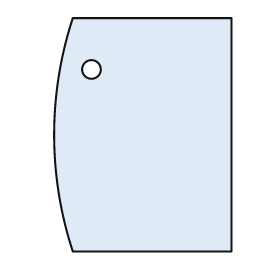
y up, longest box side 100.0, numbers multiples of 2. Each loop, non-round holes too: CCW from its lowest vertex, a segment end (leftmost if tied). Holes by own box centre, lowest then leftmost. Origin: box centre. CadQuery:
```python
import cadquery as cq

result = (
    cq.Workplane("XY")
    .moveTo(-30.0, -50.0)
    .lineTo(38.0, -50.0)
    .lineTo(38.0, 50.0)
    .lineTo(-30.0, 50.0)
    .threePointArc((-38.0, 0.0), (-30.0, -50.0))
    .close()
    .moveTo(-22.0, 28.0)
    .circle(4.0)
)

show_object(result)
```